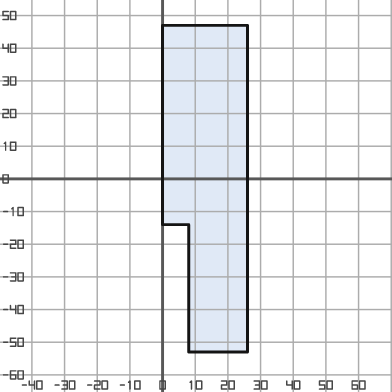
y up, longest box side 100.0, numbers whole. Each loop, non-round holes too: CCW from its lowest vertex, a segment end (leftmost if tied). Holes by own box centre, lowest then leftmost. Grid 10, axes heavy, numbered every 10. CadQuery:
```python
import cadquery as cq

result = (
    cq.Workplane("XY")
    .moveTo(8.0, -53.0)
    .lineTo(26.0, -53.0)
    .lineTo(26.0, 47.0)
    .lineTo(0.0, 47.0)
    .lineTo(0.0, -14.0)
    .lineTo(8.0, -14.0)
    .close()
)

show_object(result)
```